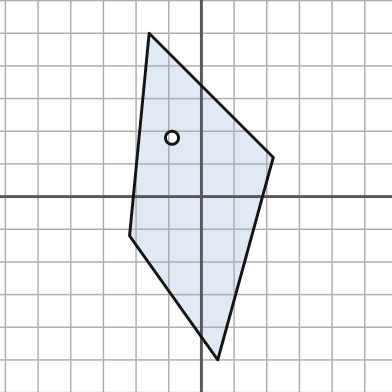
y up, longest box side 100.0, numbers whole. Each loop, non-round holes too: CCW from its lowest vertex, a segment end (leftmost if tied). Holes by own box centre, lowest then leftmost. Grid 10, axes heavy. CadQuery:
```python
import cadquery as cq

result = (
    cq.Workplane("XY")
    .moveTo(5.0, -50.0)
    .lineTo(22.0, 12.0)
    .lineTo(-16.0, 50.0)
    .lineTo(-22.0, -12.0)
    .close()
    .moveTo(-9.0, 18.0)
    .circle(2.0)
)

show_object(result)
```